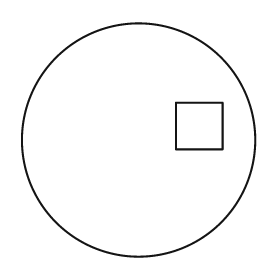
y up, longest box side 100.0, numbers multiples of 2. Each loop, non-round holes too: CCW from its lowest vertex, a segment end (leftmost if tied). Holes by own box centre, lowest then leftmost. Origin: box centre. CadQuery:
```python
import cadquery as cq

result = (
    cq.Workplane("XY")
    .moveTo(0.0, 0.0)
    .circle(50.0)
    .moveTo(16.0, -4.0)
    .lineTo(36.0, -4.0)
    .lineTo(36.0, 16.0)
    .lineTo(16.0, 16.0)
    .close()
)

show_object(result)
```